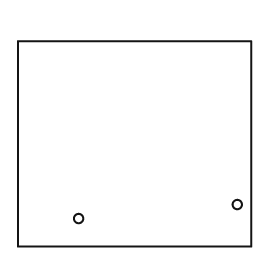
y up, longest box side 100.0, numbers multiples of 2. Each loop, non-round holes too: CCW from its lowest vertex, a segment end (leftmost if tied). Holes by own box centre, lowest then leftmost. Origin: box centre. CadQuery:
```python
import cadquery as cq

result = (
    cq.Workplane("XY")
    .moveTo(-50.0, -44.0)
    .lineTo(50.0, -44.0)
    .lineTo(50.0, 44.0)
    .lineTo(-50.0, 44.0)
    .close()
    .moveTo(-24.0, -32.0)
    .circle(2.0)
    .moveTo(44.0, -26.0)
    .circle(2.0)
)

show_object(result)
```